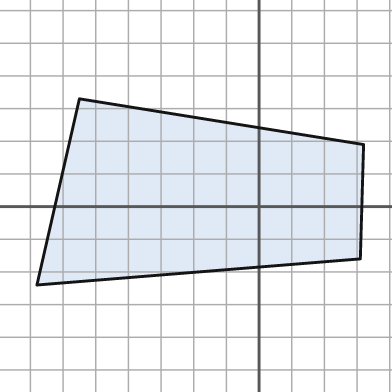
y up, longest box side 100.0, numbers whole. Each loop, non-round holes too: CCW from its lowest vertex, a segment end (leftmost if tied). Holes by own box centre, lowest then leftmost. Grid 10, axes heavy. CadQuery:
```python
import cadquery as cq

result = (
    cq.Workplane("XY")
    .moveTo(-68.0, -24.0)
    .lineTo(31.0, -16.0)
    .lineTo(32.0, 19.0)
    .lineTo(-55.0, 33.0)
    .close()
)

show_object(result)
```